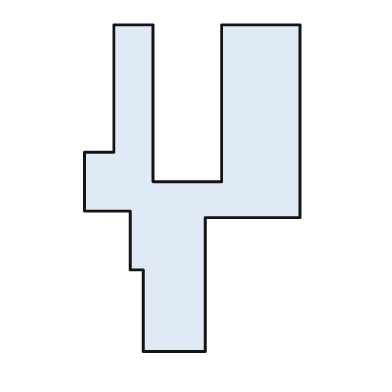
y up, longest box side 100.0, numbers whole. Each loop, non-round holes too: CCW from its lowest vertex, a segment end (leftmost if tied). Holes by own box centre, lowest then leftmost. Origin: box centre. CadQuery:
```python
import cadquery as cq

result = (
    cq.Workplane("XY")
    .moveTo(-15.0, -50.0)
    .lineTo(4.0, -50.0)
    .lineTo(4.0, -9.0)
    .lineTo(33.0, -9.0)
    .lineTo(33.0, 50.0)
    .lineTo(9.0, 50.0)
    .lineTo(9.0, 2.0)
    .lineTo(-12.0, 2.0)
    .lineTo(-12.0, 50.0)
    .lineTo(-24.0, 50.0)
    .lineTo(-24.0, 11.0)
    .lineTo(-33.0, 11.0)
    .lineTo(-33.0, -7.0)
    .lineTo(-19.0, -7.0)
    .lineTo(-19.0, -25.0)
    .lineTo(-15.0, -25.0)
    .close()
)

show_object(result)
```